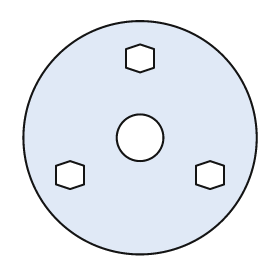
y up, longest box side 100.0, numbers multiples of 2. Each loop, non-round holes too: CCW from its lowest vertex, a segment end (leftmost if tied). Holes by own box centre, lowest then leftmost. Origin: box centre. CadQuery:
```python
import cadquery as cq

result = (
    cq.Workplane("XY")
    .moveTo(0.0, 0.0)
    .circle(50.0)
    .moveTo(-30.0, -22.0)
    .lineTo(-24.0, -20.0)
    .lineTo(-24.0, -12.0)
    .lineTo(-30.0, -10.0)
    .lineTo(-36.0, -12.0)
    .lineTo(-36.0, -20.0)
    .close()
    .moveTo(30.0, -22.0)
    .lineTo(36.0, -20.0)
    .lineTo(36.0, -12.0)
    .lineTo(30.0, -10.0)
    .lineTo(24.0, -12.0)
    .lineTo(24.0, -20.0)
    .close()
    .moveTo(0.0, 0.0)
    .circle(10.0)
    .moveTo(0.0, 28.0)
    .lineTo(6.0, 30.0)
    .lineTo(6.0, 38.0)
    .lineTo(0.0, 40.0)
    .lineTo(-6.0, 38.0)
    .lineTo(-6.0, 30.0)
    .close()
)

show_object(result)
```